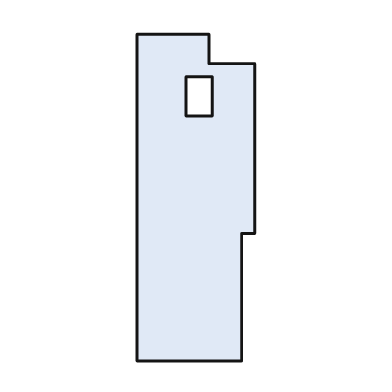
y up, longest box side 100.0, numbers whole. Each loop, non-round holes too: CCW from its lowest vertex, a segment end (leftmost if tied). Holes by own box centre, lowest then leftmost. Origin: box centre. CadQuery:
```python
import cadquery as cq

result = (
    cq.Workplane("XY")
    .moveTo(-18.0, -50.0)
    .lineTo(14.0, -50.0)
    .lineTo(14.0, -11.0)
    .lineTo(18.0, -11.0)
    .lineTo(18.0, 41.0)
    .lineTo(4.0, 41.0)
    .lineTo(4.0, 50.0)
    .lineTo(-18.0, 50.0)
    .close()
    .moveTo(-3.0, 25.0)
    .lineTo(5.0, 25.0)
    .lineTo(5.0, 37.0)
    .lineTo(-3.0, 37.0)
    .close()
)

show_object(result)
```